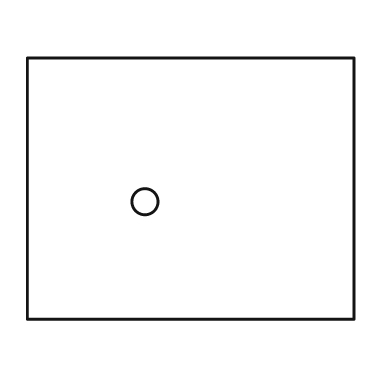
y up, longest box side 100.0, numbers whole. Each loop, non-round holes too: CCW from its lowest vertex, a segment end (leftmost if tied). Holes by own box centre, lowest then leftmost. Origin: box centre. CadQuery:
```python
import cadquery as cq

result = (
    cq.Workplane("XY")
    .moveTo(-50.0, -40.0)
    .lineTo(50.0, -40.0)
    .lineTo(50.0, 40.0)
    .lineTo(-50.0, 40.0)
    .close()
    .moveTo(-14.0, -4.0)
    .circle(4.0)
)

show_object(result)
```